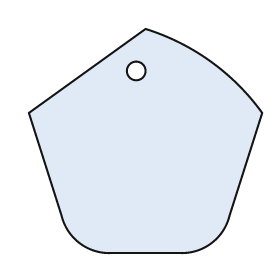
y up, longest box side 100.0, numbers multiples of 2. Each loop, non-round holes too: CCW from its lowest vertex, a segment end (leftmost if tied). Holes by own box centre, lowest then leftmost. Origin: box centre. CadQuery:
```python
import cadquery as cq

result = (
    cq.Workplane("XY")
    .moveTo(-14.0, -48.0)
    .lineTo(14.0, -48.0)
    .threePointArc((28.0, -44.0), (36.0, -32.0))
    .lineTo(50.0, 12.0)
    .threePointArc((28.0, 34.0), (0.0, 48.0))
    .lineTo(-50.0, 12.0)
    .lineTo(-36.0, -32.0)
    .threePointArc((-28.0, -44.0), (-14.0, -48.0))
    .close()
    .moveTo(-4.0, 30.0)
    .circle(4.0)
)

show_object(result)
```